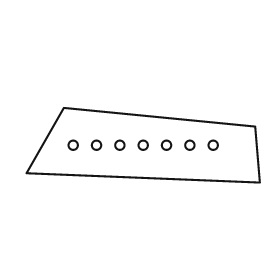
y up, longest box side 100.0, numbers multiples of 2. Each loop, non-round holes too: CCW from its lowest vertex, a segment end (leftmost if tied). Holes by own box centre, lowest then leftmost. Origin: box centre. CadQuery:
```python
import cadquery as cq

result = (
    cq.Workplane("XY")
    .moveTo(50.0, -16.0)
    .lineTo(48.0, 8.0)
    .lineTo(-34.0, 16.0)
    .lineTo(-50.0, -12.0)
    .close()
    .moveTo(-30.0, 0.0)
    .circle(2.0)
    .moveTo(-20.0, 0.0)
    .circle(2.0)
    .moveTo(-10.0, 0.0)
    .circle(2.0)
    .moveTo(0.0, 0.0)
    .circle(2.0)
    .moveTo(10.0, 0.0)
    .circle(2.0)
    .moveTo(20.0, 0.0)
    .circle(2.0)
    .moveTo(30.0, 0.0)
    .circle(2.0)
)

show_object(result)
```